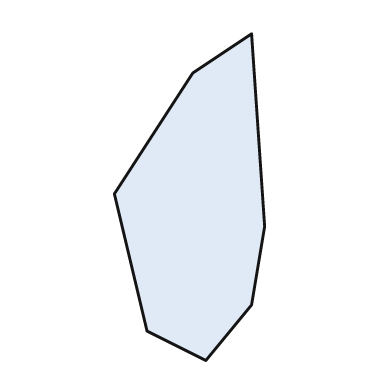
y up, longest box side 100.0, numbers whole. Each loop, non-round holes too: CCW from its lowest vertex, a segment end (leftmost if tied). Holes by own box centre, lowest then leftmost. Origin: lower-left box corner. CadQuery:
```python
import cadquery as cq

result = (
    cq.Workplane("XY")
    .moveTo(28.0, 0.0)
    .lineTo(42.0, 17.0)
    .lineTo(46.0, 41.0)
    .lineTo(42.0, 100.0)
    .lineTo(24.0, 88.0)
    .lineTo(0.0, 51.0)
    .lineTo(10.0, 9.0)
    .close()
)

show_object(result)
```